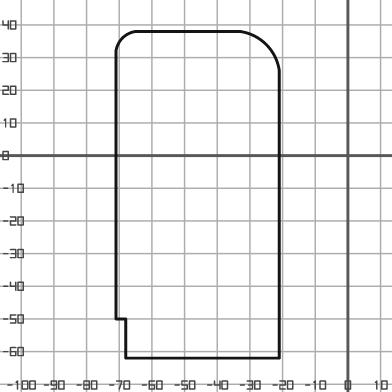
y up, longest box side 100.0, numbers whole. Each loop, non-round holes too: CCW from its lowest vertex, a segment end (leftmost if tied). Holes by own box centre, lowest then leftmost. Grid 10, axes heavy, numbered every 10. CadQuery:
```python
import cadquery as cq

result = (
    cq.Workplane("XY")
    .moveTo(-68.0, -62.0)
    .lineTo(-21.0, -62.0)
    .lineTo(-21.0, 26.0)
    .threePointArc((-25.0, 34.0), (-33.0, 38.0))
    .lineTo(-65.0, 38.0)
    .threePointArc((-69.0, 36.0), (-71.0, 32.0))
    .lineTo(-71.0, -50.0)
    .lineTo(-68.0, -50.0)
    .close()
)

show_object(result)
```